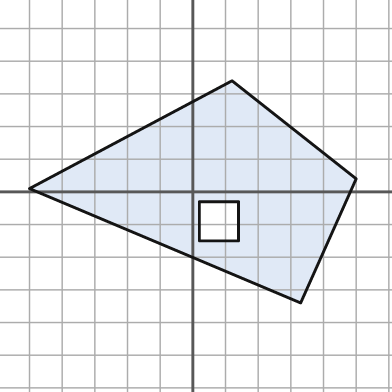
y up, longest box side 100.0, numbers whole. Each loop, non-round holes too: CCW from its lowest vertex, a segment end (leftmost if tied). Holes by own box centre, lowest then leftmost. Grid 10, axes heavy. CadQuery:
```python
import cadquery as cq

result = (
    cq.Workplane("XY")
    .moveTo(33.0, -34.0)
    .lineTo(50.0, 4.0)
    .lineTo(12.0, 34.0)
    .lineTo(-50.0, 1.0)
    .close()
    .moveTo(2.0, -15.0)
    .lineTo(14.0, -15.0)
    .lineTo(14.0, -3.0)
    .lineTo(2.0, -3.0)
    .close()
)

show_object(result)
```